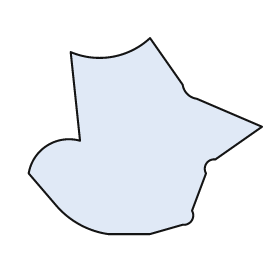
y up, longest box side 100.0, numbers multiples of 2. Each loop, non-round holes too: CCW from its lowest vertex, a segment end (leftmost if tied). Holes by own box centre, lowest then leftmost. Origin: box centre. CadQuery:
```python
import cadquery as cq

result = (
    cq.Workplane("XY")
    .moveTo(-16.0, -42.0)
    .lineTo(2.0, -42.0)
    .lineTo(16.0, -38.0)
    .threePointArc((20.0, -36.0), (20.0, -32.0))
    .lineTo(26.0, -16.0)
    .threePointArc((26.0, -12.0), (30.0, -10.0))
    .lineTo(50.0, 4.0)
    .lineTo(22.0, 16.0)
    .threePointArc((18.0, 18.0), (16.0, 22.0))
    .lineTo(2.0, 42.0)
    .threePointArc((-14.0, 34.0), (-32.0, 36.0))
    .lineTo(-28.0, -2.0)
    .threePointArc((-42.0, -4.0), (-50.0, -16.0))
    .lineTo(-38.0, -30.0)
    .threePointArc((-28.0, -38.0), (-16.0, -42.0))
    .close()
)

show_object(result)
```